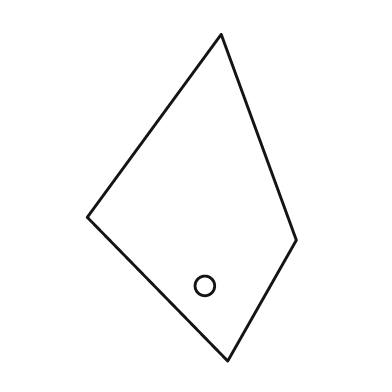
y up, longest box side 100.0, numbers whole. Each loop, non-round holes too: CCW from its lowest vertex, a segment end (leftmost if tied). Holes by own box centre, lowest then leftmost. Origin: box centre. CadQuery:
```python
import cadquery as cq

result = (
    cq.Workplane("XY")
    .moveTo(11.0, -50.0)
    .lineTo(32.0, -13.0)
    .lineTo(9.0, 50.0)
    .lineTo(-32.0, -6.0)
    .close()
    .moveTo(4.0, -27.0)
    .circle(3.0)
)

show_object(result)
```